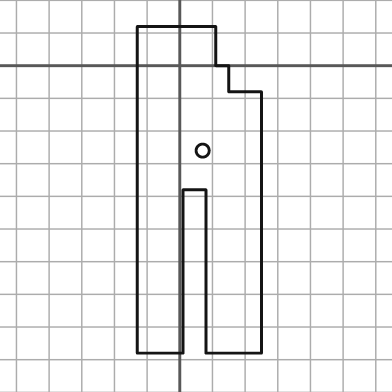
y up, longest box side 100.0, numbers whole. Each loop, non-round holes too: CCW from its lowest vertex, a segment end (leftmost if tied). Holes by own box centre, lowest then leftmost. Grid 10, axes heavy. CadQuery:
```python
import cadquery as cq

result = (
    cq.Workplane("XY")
    .moveTo(-13.0, -88.0)
    .lineTo(1.0, -88.0)
    .lineTo(1.0, -38.0)
    .lineTo(8.0, -38.0)
    .lineTo(8.0, -88.0)
    .lineTo(25.0, -88.0)
    .lineTo(25.0, -8.0)
    .lineTo(15.0, -8.0)
    .lineTo(15.0, 0.0)
    .lineTo(11.0, 0.0)
    .lineTo(11.0, 12.0)
    .lineTo(-13.0, 12.0)
    .close()
    .moveTo(7.0, -26.0)
    .circle(2.0)
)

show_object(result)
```